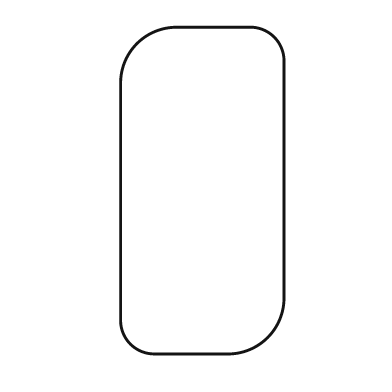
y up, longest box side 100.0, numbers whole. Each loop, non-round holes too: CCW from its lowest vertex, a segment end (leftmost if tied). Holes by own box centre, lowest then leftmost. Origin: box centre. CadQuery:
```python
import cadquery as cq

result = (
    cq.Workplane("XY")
    .moveTo(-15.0, -50.0)
    .lineTo(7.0, -50.0)
    .threePointArc((20.0, -45.0), (25.0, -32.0))
    .lineTo(25.0, 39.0)
    .threePointArc((22.0, 47.0), (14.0, 50.0))
    .lineTo(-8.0, 50.0)
    .threePointArc((-20.0, 45.0), (-25.0, 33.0))
    .lineTo(-25.0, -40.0)
    .threePointArc((-22.0, -47.0), (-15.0, -50.0))
    .close()
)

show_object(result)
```